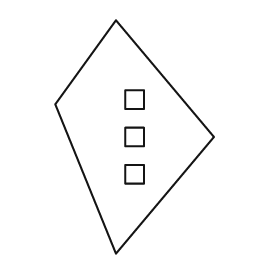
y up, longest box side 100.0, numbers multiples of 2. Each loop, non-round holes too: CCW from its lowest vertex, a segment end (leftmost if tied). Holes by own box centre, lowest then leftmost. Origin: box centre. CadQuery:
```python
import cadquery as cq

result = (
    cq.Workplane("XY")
    .moveTo(-8.0, -50.0)
    .lineTo(34.0, 0.0)
    .lineTo(-8.0, 50.0)
    .lineTo(-34.0, 14.0)
    .close()
    .moveTo(-4.0, -20.0)
    .lineTo(4.0, -20.0)
    .lineTo(4.0, -12.0)
    .lineTo(-4.0, -12.0)
    .close()
    .moveTo(-4.0, -4.0)
    .lineTo(4.0, -4.0)
    .lineTo(4.0, 4.0)
    .lineTo(-4.0, 4.0)
    .close()
    .moveTo(-4.0, 12.0)
    .lineTo(4.0, 12.0)
    .lineTo(4.0, 20.0)
    .lineTo(-4.0, 20.0)
    .close()
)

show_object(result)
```